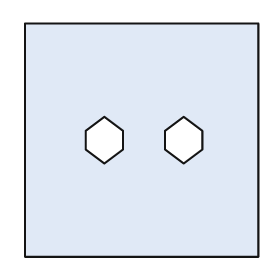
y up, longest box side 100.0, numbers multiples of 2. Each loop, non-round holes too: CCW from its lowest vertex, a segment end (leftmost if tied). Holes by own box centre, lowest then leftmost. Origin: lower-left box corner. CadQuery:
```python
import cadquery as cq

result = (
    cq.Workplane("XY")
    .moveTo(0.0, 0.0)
    .lineTo(100.0, 0.0)
    .lineTo(100.0, 100.0)
    .lineTo(0.0, 100.0)
    .close()
    .moveTo(34.0, 40.0)
    .lineTo(42.0, 46.0)
    .lineTo(42.0, 54.0)
    .lineTo(34.0, 60.0)
    .lineTo(26.0, 54.0)
    .lineTo(26.0, 46.0)
    .close()
    .moveTo(68.0, 40.0)
    .lineTo(76.0, 46.0)
    .lineTo(76.0, 54.0)
    .lineTo(68.0, 60.0)
    .lineTo(60.0, 54.0)
    .lineTo(60.0, 46.0)
    .close()
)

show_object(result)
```